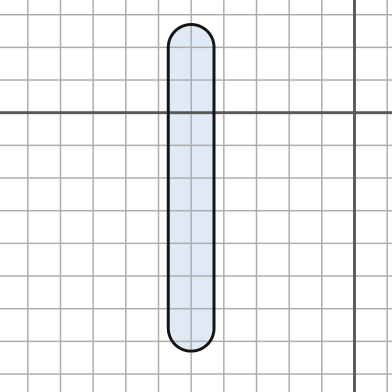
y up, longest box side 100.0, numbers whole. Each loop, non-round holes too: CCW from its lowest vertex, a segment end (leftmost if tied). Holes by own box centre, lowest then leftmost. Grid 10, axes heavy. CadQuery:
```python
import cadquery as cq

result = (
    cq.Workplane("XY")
    .moveTo(-57.0, -66.0)
    .threePointArc((-50.0, -73.0), (-43.0, -66.0))
    .lineTo(-43.0, 20.0)
    .threePointArc((-50.0, 27.0), (-57.0, 20.0))
    .close()
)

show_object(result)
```